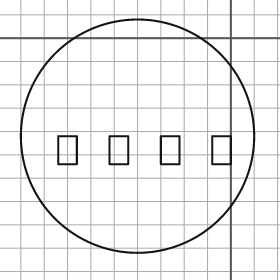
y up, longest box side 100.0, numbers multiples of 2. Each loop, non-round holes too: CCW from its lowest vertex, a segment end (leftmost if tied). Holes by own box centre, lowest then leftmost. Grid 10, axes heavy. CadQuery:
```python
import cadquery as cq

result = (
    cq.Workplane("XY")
    .moveTo(-40.0, -42.0)
    .circle(50.0)
    .moveTo(-74.0, -54.0)
    .lineTo(-66.0, -54.0)
    .lineTo(-66.0, -42.0)
    .lineTo(-74.0, -42.0)
    .close()
    .moveTo(-52.0, -54.0)
    .lineTo(-44.0, -54.0)
    .lineTo(-44.0, -42.0)
    .lineTo(-52.0, -42.0)
    .close()
    .moveTo(-30.0, -54.0)
    .lineTo(-22.0, -54.0)
    .lineTo(-22.0, -42.0)
    .lineTo(-30.0, -42.0)
    .close()
    .moveTo(-8.0, -54.0)
    .lineTo(0.0, -54.0)
    .lineTo(0.0, -42.0)
    .lineTo(-8.0, -42.0)
    .close()
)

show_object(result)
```